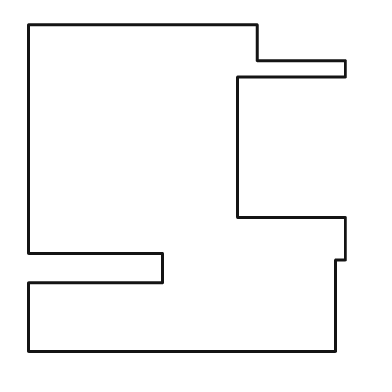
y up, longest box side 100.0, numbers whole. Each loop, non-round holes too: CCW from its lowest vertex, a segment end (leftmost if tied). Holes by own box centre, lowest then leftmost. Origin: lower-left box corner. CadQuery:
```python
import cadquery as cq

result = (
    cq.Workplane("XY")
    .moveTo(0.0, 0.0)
    .lineTo(94.0, 0.0)
    .lineTo(94.0, 28.0)
    .lineTo(97.0, 28.0)
    .lineTo(97.0, 41.0)
    .lineTo(64.0, 41.0)
    .lineTo(64.0, 84.0)
    .lineTo(97.0, 84.0)
    .lineTo(97.0, 89.0)
    .lineTo(70.0, 89.0)
    .lineTo(70.0, 100.0)
    .lineTo(0.0, 100.0)
    .lineTo(0.0, 30.0)
    .lineTo(41.0, 30.0)
    .lineTo(41.0, 21.0)
    .lineTo(0.0, 21.0)
    .close()
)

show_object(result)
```